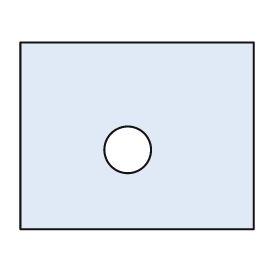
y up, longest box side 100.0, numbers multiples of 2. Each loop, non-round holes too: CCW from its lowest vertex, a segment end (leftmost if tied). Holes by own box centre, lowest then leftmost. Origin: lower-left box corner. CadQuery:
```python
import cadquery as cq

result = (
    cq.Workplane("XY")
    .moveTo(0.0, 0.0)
    .lineTo(100.0, 0.0)
    .lineTo(100.0, 80.0)
    .lineTo(0.0, 80.0)
    .close()
    .moveTo(46.0, 34.0)
    .circle(10.0)
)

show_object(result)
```